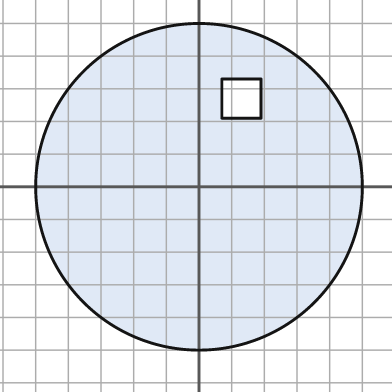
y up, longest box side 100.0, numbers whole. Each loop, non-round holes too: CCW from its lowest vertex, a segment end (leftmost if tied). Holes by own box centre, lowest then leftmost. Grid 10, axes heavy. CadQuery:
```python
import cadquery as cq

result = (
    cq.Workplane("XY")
    .moveTo(0.0, 0.0)
    .circle(50.0)
    .moveTo(7.0, 21.0)
    .lineTo(19.0, 21.0)
    .lineTo(19.0, 33.0)
    .lineTo(7.0, 33.0)
    .close()
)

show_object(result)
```